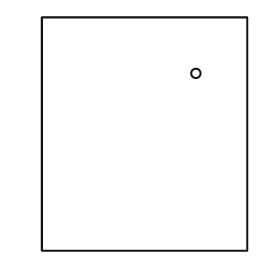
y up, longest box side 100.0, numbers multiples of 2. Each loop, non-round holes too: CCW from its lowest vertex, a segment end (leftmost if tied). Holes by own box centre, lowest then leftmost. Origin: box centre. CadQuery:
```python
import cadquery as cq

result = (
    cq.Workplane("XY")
    .moveTo(-44.0, -50.0)
    .lineTo(44.0, -50.0)
    .lineTo(44.0, 50.0)
    .lineTo(-44.0, 50.0)
    .close()
    .moveTo(22.0, 26.0)
    .circle(2.0)
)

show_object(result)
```